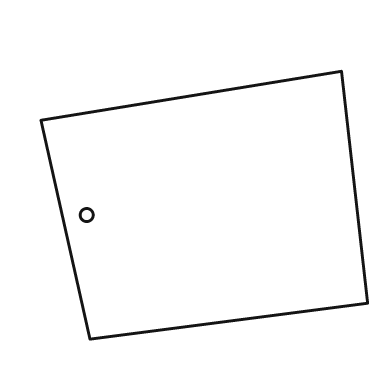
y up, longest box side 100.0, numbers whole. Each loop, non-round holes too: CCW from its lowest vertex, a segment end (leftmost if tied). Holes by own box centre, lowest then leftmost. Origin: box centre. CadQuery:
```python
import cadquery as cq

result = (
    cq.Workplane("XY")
    .moveTo(-35.0, -41.0)
    .lineTo(50.0, -30.0)
    .lineTo(42.0, 41.0)
    .lineTo(-50.0, 26.0)
    .close()
    .moveTo(-36.0, -3.0)
    .circle(2.0)
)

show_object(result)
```